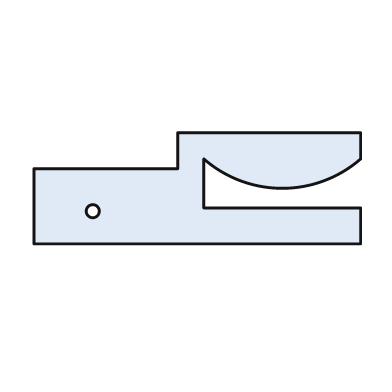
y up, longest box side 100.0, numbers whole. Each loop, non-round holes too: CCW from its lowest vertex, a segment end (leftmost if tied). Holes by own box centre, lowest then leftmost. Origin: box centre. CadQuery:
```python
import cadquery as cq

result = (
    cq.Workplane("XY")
    .moveTo(-50.0, -17.0)
    .lineTo(50.0, -17.0)
    .lineTo(50.0, -6.0)
    .lineTo(2.0, -6.0)
    .lineTo(2.0, 9.0)
    .threePointArc((26.0, 0.0), (50.0, 9.0))
    .lineTo(50.0, 17.0)
    .lineTo(-6.0, 17.0)
    .lineTo(-6.0, 6.0)
    .lineTo(-50.0, 6.0)
    .close()
    .moveTo(-32.0, -7.0)
    .circle(2.0)
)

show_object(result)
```